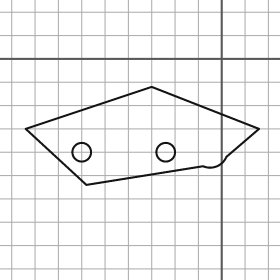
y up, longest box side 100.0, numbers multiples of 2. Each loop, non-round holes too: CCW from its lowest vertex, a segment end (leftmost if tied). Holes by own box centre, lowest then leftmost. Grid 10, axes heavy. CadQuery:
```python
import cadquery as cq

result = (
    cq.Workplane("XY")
    .moveTo(-58.0, -54.0)
    .lineTo(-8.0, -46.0)
    .threePointArc((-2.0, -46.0), (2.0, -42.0))
    .lineTo(16.0, -30.0)
    .lineTo(-30.0, -12.0)
    .lineTo(-84.0, -30.0)
    .close()
    .moveTo(-60.0, -40.0)
    .circle(4.0)
    .moveTo(-24.0, -40.0)
    .circle(4.0)
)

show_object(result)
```